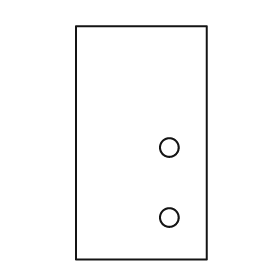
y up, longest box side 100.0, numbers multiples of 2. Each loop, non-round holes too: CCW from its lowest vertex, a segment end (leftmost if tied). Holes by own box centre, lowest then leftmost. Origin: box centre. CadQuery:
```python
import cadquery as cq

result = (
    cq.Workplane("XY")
    .moveTo(-28.0, -50.0)
    .lineTo(28.0, -50.0)
    .lineTo(28.0, 50.0)
    .lineTo(-28.0, 50.0)
    .close()
    .moveTo(12.0, -32.0)
    .circle(4.0)
    .moveTo(12.0, -2.0)
    .circle(4.0)
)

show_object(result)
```